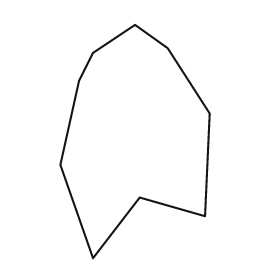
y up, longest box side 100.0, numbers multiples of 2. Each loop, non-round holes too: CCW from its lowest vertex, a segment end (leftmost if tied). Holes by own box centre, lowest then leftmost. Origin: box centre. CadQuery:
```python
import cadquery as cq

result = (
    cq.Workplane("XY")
    .moveTo(-18.0, -50.0)
    .lineTo(2.0, -24.0)
    .lineTo(30.0, -32.0)
    .lineTo(32.0, 12.0)
    .lineTo(14.0, 40.0)
    .lineTo(0.0, 50.0)
    .lineTo(-18.0, 38.0)
    .lineTo(-24.0, 26.0)
    .lineTo(-32.0, -10.0)
    .close()
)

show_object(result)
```